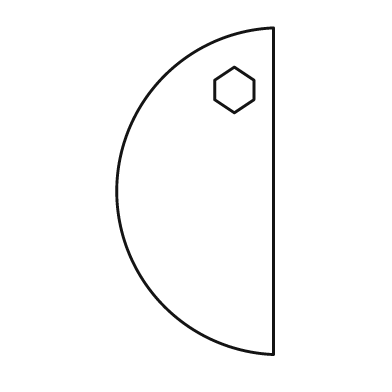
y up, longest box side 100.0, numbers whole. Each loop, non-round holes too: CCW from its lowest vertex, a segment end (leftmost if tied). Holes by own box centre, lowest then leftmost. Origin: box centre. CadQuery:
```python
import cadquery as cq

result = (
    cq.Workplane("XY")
    .moveTo(24.0, -50.0)
    .lineTo(24.0, 50.0)
    .threePointArc((-24.0, 0.0), (24.0, -50.0))
    .close()
    .moveTo(12.0, 24.0)
    .lineTo(18.0, 28.0)
    .lineTo(18.0, 34.0)
    .lineTo(12.0, 38.0)
    .lineTo(6.0, 34.0)
    .lineTo(6.0, 28.0)
    .close()
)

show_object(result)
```